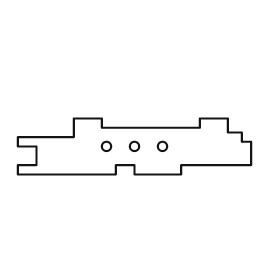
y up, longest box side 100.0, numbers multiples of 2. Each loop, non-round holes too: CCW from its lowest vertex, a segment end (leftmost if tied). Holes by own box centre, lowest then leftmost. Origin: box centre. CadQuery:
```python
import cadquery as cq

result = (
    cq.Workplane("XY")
    .moveTo(-50.0, -12.0)
    .lineTo(-8.0, -12.0)
    .lineTo(-8.0, -8.0)
    .lineTo(0.0, -8.0)
    .lineTo(0.0, -12.0)
    .lineTo(20.0, -12.0)
    .lineTo(20.0, -8.0)
    .lineTo(50.0, -8.0)
    .lineTo(50.0, 2.0)
    .lineTo(46.0, 2.0)
    .lineTo(46.0, 6.0)
    .lineTo(40.0, 6.0)
    .lineTo(40.0, 12.0)
    .lineTo(28.0, 12.0)
    .lineTo(28.0, 8.0)
    .lineTo(-14.0, 8.0)
    .lineTo(-14.0, 12.0)
    .lineTo(-26.0, 12.0)
    .lineTo(-26.0, 4.0)
    .lineTo(-50.0, 4.0)
    .lineTo(-50.0, 0.0)
    .lineTo(-42.0, 0.0)
    .lineTo(-42.0, -8.0)
    .lineTo(-50.0, -8.0)
    .close()
    .moveTo(-12.0, 0.0)
    .circle(2.0)
    .moveTo(0.0, 0.0)
    .circle(2.0)
    .moveTo(12.0, 0.0)
    .circle(2.0)
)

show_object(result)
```